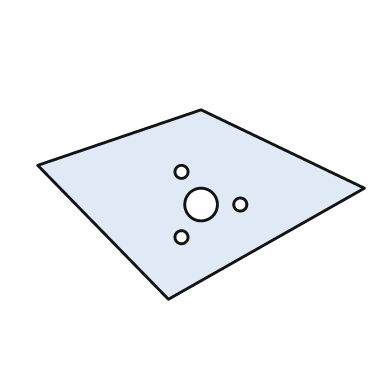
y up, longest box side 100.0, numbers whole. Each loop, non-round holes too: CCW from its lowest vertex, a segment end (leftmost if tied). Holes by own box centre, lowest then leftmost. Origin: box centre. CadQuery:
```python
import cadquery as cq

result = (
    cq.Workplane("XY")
    .moveTo(-10.0, -29.0)
    .lineTo(50.0, 5.0)
    .lineTo(0.0, 29.0)
    .lineTo(-50.0, 12.0)
    .close()
    .moveTo(-6.0, -10.0)
    .circle(2.0)
    .moveTo(0.0, 0.0)
    .circle(5.0)
    .moveTo(12.0, 0.0)
    .circle(2.0)
    .moveTo(-6.0, 10.0)
    .circle(2.0)
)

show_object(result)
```